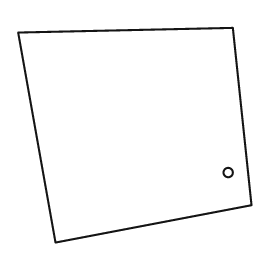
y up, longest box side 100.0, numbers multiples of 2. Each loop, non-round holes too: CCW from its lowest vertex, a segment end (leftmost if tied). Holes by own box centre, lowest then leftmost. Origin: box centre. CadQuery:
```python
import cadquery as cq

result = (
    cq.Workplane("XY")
    .moveTo(-34.0, -46.0)
    .lineTo(50.0, -30.0)
    .lineTo(42.0, 46.0)
    .lineTo(-50.0, 44.0)
    .close()
    .moveTo(40.0, -16.0)
    .circle(2.0)
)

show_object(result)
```